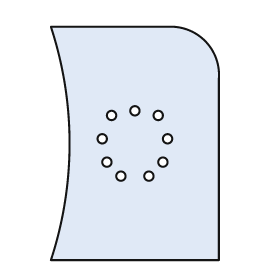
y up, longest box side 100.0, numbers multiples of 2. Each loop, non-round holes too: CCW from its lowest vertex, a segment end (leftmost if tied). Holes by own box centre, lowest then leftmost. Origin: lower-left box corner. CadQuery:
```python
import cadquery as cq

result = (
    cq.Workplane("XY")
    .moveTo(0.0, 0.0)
    .lineTo(72.0, 0.0)
    .lineTo(72.0, 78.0)
    .threePointArc((66.0, 94.0), (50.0, 100.0))
    .lineTo(0.0, 100.0)
    .threePointArc((8.0, 50.0), (0.0, 0.0))
    .close()
    .moveTo(30.0, 36.0)
    .circle(2.0)
    .moveTo(42.0, 36.0)
    .circle(2.0)
    .moveTo(24.0, 42.0)
    .circle(2.0)
    .moveTo(48.0, 42.0)
    .circle(2.0)
    .moveTo(22.0, 52.0)
    .circle(2.0)
    .moveTo(50.0, 52.0)
    .circle(2.0)
    .moveTo(26.0, 62.0)
    .circle(2.0)
    .moveTo(46.0, 62.0)
    .circle(2.0)
    .moveTo(36.0, 64.0)
    .circle(2.0)
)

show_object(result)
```